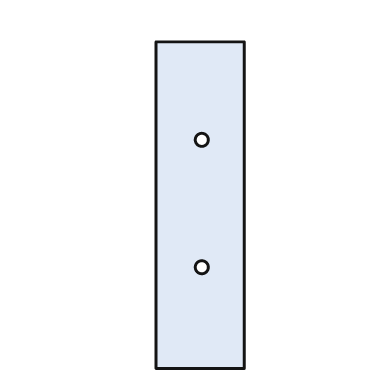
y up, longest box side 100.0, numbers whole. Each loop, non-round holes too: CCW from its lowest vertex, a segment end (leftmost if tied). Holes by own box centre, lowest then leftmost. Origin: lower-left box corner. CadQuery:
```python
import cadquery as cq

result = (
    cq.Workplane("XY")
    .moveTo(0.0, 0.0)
    .lineTo(27.0, 0.0)
    .lineTo(27.0, 100.0)
    .lineTo(0.0, 100.0)
    .close()
    .moveTo(14.0, 31.0)
    .circle(2.0)
    .moveTo(14.0, 70.0)
    .circle(2.0)
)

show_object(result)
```